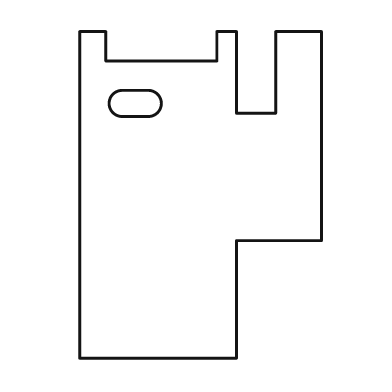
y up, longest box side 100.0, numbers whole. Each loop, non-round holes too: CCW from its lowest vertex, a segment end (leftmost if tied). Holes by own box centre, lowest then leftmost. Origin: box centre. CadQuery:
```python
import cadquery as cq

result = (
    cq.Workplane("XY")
    .moveTo(-37.0, -50.0)
    .lineTo(11.0, -50.0)
    .lineTo(11.0, -14.0)
    .lineTo(37.0, -14.0)
    .lineTo(37.0, 50.0)
    .lineTo(23.0, 50.0)
    .lineTo(23.0, 25.0)
    .lineTo(11.0, 25.0)
    .lineTo(11.0, 50.0)
    .lineTo(5.0, 50.0)
    .lineTo(5.0, 41.0)
    .lineTo(-29.0, 41.0)
    .lineTo(-29.0, 50.0)
    .lineTo(-37.0, 50.0)
    .close()
    .moveTo(-24.0, 24.0)
    .lineTo(-16.0, 24.0)
    .threePointArc((-12.0, 28.0), (-16.0, 32.0))
    .lineTo(-24.0, 32.0)
    .threePointArc((-28.0, 28.0), (-24.0, 24.0))
    .close()
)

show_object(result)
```